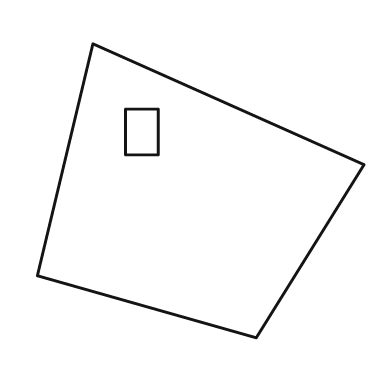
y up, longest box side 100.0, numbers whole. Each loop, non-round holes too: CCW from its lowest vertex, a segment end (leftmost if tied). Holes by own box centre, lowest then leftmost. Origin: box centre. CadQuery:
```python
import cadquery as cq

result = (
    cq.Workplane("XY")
    .moveTo(17.0, -45.0)
    .lineTo(50.0, 8.0)
    .lineTo(-33.0, 45.0)
    .lineTo(-50.0, -26.0)
    .close()
    .moveTo(-23.0, 11.0)
    .lineTo(-13.0, 11.0)
    .lineTo(-13.0, 25.0)
    .lineTo(-23.0, 25.0)
    .close()
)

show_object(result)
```